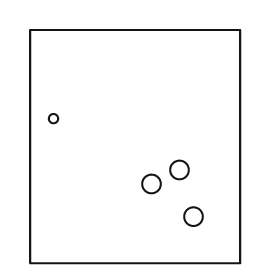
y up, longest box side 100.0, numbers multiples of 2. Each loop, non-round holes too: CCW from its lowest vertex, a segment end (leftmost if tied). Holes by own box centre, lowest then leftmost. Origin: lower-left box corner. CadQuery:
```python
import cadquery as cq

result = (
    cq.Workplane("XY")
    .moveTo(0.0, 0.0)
    .lineTo(90.0, 0.0)
    .lineTo(90.0, 100.0)
    .lineTo(0.0, 100.0)
    .close()
    .moveTo(70.0, 20.0)
    .circle(4.0)
    .moveTo(52.0, 34.0)
    .circle(4.0)
    .moveTo(64.0, 40.0)
    .circle(4.0)
    .moveTo(10.0, 62.0)
    .circle(2.0)
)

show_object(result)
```